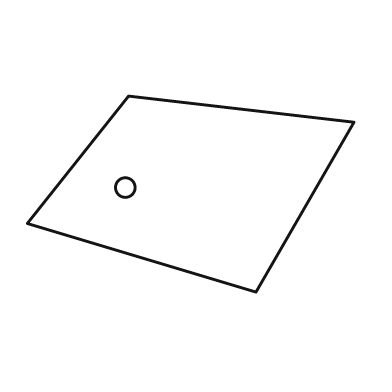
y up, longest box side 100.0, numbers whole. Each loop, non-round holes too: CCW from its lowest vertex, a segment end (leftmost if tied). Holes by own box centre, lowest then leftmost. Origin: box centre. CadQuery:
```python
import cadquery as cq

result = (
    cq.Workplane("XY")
    .moveTo(20.0, -30.0)
    .lineTo(50.0, 22.0)
    .lineTo(-19.0, 30.0)
    .lineTo(-50.0, -9.0)
    .close()
    .moveTo(-20.0, 2.0)
    .circle(3.0)
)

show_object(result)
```